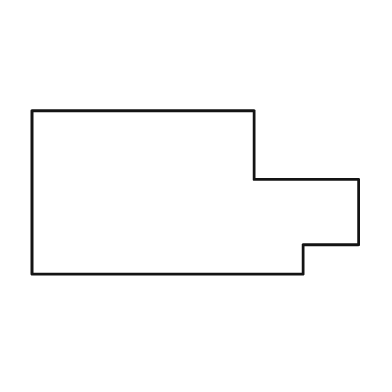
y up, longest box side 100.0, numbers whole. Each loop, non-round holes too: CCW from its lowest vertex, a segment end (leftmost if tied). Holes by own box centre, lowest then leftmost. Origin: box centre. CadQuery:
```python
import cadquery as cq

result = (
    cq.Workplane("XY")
    .moveTo(-50.0, -25.0)
    .lineTo(33.0, -25.0)
    .lineTo(33.0, -16.0)
    .lineTo(50.0, -16.0)
    .lineTo(50.0, 4.0)
    .lineTo(18.0, 4.0)
    .lineTo(18.0, 25.0)
    .lineTo(-50.0, 25.0)
    .close()
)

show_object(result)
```